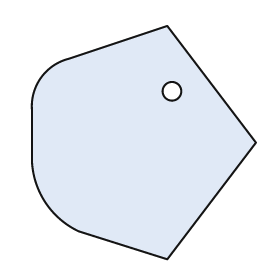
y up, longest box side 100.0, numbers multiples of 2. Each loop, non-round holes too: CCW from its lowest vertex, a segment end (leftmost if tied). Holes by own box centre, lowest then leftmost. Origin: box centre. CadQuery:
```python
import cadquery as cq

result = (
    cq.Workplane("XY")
    .moveTo(10.0, -50.0)
    .lineTo(48.0, 0.0)
    .lineTo(10.0, 50.0)
    .lineTo(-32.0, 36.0)
    .threePointArc((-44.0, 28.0), (-48.0, 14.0))
    .lineTo(-48.0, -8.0)
    .threePointArc((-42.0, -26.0), (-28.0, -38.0))
    .close()
    .moveTo(12.0, 22.0)
    .circle(4.0)
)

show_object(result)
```